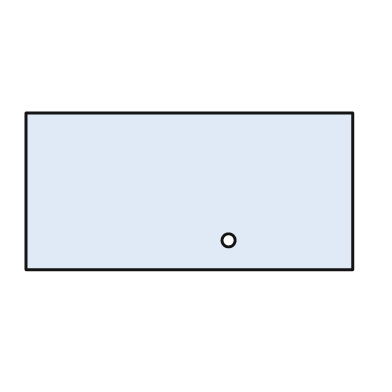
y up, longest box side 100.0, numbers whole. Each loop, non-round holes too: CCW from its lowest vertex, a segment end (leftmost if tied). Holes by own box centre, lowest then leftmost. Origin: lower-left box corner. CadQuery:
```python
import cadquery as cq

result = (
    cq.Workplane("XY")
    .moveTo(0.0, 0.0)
    .lineTo(100.0, 0.0)
    .lineTo(100.0, 48.0)
    .lineTo(0.0, 48.0)
    .close()
    .moveTo(62.0, 9.0)
    .circle(2.0)
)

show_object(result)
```